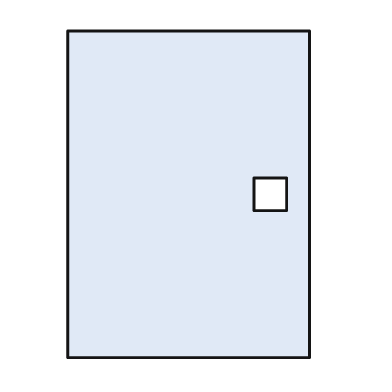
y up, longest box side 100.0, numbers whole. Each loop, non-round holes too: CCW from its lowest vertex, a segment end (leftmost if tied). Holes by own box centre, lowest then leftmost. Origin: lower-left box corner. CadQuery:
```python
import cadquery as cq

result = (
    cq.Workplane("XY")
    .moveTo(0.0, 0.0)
    .lineTo(74.0, 0.0)
    .lineTo(74.0, 100.0)
    .lineTo(0.0, 100.0)
    .close()
    .moveTo(57.0, 45.0)
    .lineTo(67.0, 45.0)
    .lineTo(67.0, 55.0)
    .lineTo(57.0, 55.0)
    .close()
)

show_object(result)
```